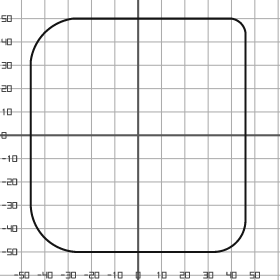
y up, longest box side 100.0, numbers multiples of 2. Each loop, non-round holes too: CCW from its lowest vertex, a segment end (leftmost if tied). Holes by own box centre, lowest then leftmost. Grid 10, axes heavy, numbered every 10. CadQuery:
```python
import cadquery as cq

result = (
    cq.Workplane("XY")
    .moveTo(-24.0, -50.0)
    .lineTo(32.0, -50.0)
    .threePointArc((42.0, -46.0), (46.0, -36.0))
    .lineTo(46.0, 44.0)
    .threePointArc((44.0, 48.0), (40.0, 50.0))
    .lineTo(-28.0, 50.0)
    .threePointArc((-40.0, 44.0), (-46.0, 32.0))
    .lineTo(-46.0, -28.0)
    .threePointArc((-40.0, -44.0), (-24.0, -50.0))
    .close()
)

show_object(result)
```